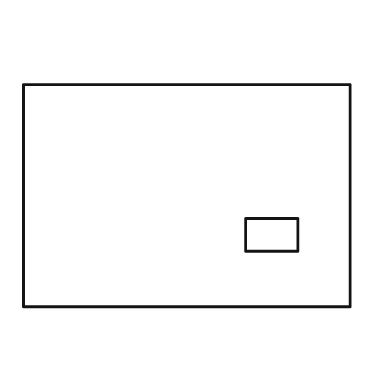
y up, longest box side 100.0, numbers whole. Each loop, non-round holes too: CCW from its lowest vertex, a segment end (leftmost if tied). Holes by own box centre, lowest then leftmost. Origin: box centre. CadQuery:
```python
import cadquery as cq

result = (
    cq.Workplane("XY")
    .moveTo(-50.0, -34.0)
    .lineTo(50.0, -34.0)
    .lineTo(50.0, 34.0)
    .lineTo(-50.0, 34.0)
    .close()
    .moveTo(18.0, -17.0)
    .lineTo(34.0, -17.0)
    .lineTo(34.0, -7.0)
    .lineTo(18.0, -7.0)
    .close()
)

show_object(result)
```